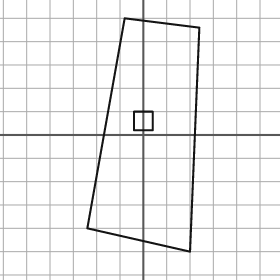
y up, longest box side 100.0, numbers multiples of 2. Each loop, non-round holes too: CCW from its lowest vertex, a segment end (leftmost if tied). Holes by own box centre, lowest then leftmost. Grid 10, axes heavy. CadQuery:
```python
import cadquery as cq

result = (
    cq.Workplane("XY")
    .moveTo(20.0, -50.0)
    .lineTo(24.0, 46.0)
    .lineTo(-8.0, 50.0)
    .lineTo(-24.0, -40.0)
    .close()
    .moveTo(-4.0, 2.0)
    .lineTo(4.0, 2.0)
    .lineTo(4.0, 10.0)
    .lineTo(-4.0, 10.0)
    .close()
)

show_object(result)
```